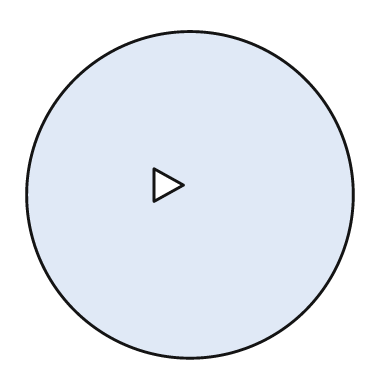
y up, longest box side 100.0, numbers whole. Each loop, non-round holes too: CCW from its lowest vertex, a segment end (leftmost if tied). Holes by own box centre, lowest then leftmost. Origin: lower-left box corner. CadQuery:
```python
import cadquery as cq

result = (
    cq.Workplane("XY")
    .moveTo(50.0, 50.0)
    .circle(50.0)
    .moveTo(39.0, 48.0)
    .lineTo(48.0, 53.0)
    .lineTo(39.0, 58.0)
    .close()
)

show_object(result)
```